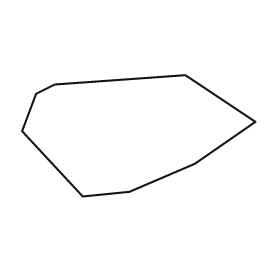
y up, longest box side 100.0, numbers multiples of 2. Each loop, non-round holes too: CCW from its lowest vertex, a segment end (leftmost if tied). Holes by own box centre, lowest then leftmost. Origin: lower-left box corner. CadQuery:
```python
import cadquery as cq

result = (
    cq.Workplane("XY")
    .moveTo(26.0, 0.0)
    .lineTo(46.0, 2.0)
    .lineTo(74.0, 14.0)
    .lineTo(100.0, 32.0)
    .lineTo(70.0, 52.0)
    .lineTo(14.0, 48.0)
    .lineTo(6.0, 44.0)
    .lineTo(0.0, 28.0)
    .close()
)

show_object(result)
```